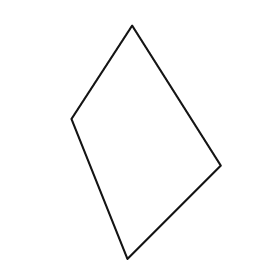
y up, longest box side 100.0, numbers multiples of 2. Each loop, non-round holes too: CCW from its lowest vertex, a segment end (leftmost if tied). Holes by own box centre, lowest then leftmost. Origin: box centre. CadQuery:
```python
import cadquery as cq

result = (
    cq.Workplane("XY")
    .moveTo(-8.0, -50.0)
    .lineTo(32.0, -10.0)
    .lineTo(-6.0, 50.0)
    .lineTo(-32.0, 10.0)
    .close()
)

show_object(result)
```